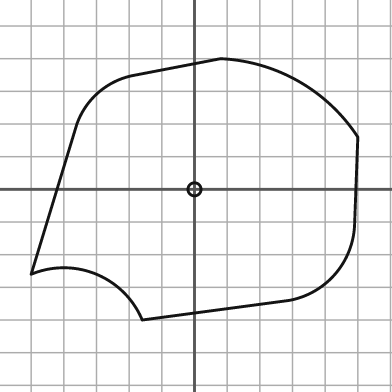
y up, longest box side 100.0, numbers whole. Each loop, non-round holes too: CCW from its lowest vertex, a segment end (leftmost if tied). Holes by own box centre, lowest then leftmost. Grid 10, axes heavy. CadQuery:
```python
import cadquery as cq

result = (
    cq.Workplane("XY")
    .moveTo(-16.0, -40.0)
    .lineTo(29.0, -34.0)
    .threePointArc((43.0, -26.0), (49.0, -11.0))
    .lineTo(50.0, 16.0)
    .threePointArc((32.0, 33.0), (8.0, 40.0))
    .lineTo(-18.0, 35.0)
    .threePointArc((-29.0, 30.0), (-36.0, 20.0))
    .lineTo(-50.0, -26.0)
    .threePointArc((-30.0, -26.0), (-16.0, -40.0))
    .close()
    .moveTo(0.0, 0.0)
    .circle(2.0)
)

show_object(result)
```